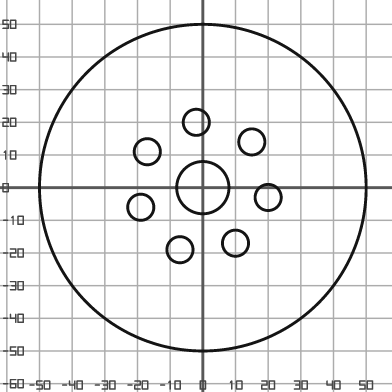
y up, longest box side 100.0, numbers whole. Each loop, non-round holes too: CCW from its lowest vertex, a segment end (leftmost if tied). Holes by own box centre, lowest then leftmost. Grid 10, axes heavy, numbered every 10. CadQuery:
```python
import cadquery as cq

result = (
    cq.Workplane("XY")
    .moveTo(0.0, 0.0)
    .circle(50.0)
    .moveTo(-7.0, -19.0)
    .circle(4.0)
    .moveTo(10.0, -17.0)
    .circle(4.0)
    .moveTo(-19.0, -6.0)
    .circle(4.0)
    .moveTo(20.0, -3.0)
    .circle(4.0)
    .moveTo(0.0, 0.0)
    .circle(8.0)
    .moveTo(-17.0, 11.0)
    .circle(4.0)
    .moveTo(15.0, 14.0)
    .circle(4.0)
    .moveTo(-2.0, 20.0)
    .circle(4.0)
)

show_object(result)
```